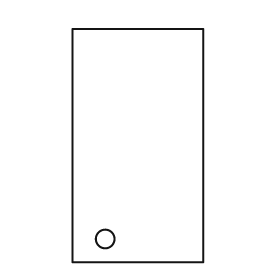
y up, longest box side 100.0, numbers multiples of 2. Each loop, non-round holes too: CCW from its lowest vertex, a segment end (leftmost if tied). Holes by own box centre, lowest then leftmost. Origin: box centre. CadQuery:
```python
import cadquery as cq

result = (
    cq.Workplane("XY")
    .moveTo(-28.0, -50.0)
    .lineTo(28.0, -50.0)
    .lineTo(28.0, 50.0)
    .lineTo(-28.0, 50.0)
    .close()
    .moveTo(-14.0, -40.0)
    .circle(4.0)
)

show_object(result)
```